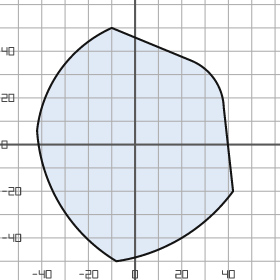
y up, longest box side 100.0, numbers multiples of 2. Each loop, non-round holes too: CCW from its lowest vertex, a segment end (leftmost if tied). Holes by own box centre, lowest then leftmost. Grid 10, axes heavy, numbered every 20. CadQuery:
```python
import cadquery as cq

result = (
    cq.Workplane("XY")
    .moveTo(-8.0, -50.0)
    .threePointArc((20.0, -40.0), (42.0, -20.0))
    .lineTo(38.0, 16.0)
    .threePointArc((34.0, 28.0), (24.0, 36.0))
    .lineTo(-10.0, 50.0)
    .threePointArc((-32.0, 32.0), (-42.0, 6.0))
    .threePointArc((-32.0, -26.0), (-8.0, -50.0))
    .close()
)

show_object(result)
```